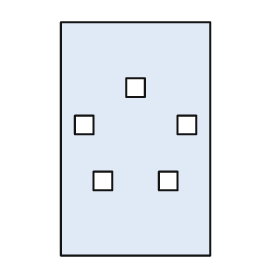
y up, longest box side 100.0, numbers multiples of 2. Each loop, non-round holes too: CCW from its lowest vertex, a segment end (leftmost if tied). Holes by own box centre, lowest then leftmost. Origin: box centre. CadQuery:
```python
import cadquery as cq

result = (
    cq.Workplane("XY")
    .moveTo(-32.0, -50.0)
    .lineTo(32.0, -50.0)
    .lineTo(32.0, 50.0)
    .lineTo(-32.0, 50.0)
    .close()
    .moveTo(-18.0, -22.0)
    .lineTo(-10.0, -22.0)
    .lineTo(-10.0, -14.0)
    .lineTo(-18.0, -14.0)
    .close()
    .moveTo(10.0, -22.0)
    .lineTo(18.0, -22.0)
    .lineTo(18.0, -14.0)
    .lineTo(10.0, -14.0)
    .close()
    .moveTo(-26.0, 2.0)
    .lineTo(-18.0, 2.0)
    .lineTo(-18.0, 10.0)
    .lineTo(-26.0, 10.0)
    .close()
    .moveTo(18.0, 2.0)
    .lineTo(26.0, 2.0)
    .lineTo(26.0, 10.0)
    .lineTo(18.0, 10.0)
    .close()
    .moveTo(-4.0, 18.0)
    .lineTo(4.0, 18.0)
    .lineTo(4.0, 26.0)
    .lineTo(-4.0, 26.0)
    .close()
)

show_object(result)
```